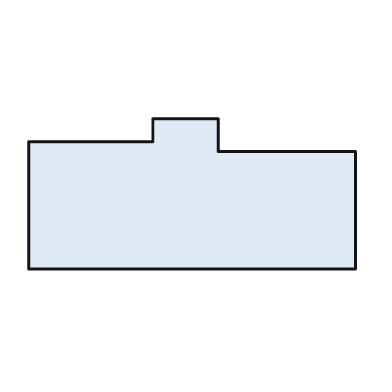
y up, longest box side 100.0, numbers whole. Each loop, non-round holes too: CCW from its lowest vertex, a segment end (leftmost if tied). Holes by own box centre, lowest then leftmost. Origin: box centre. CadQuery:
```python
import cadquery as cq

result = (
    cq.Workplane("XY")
    .moveTo(-50.0, -23.0)
    .lineTo(50.0, -23.0)
    .lineTo(50.0, 13.0)
    .lineTo(8.0, 13.0)
    .lineTo(8.0, 23.0)
    .lineTo(-12.0, 23.0)
    .lineTo(-12.0, 16.0)
    .lineTo(-50.0, 16.0)
    .close()
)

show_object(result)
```